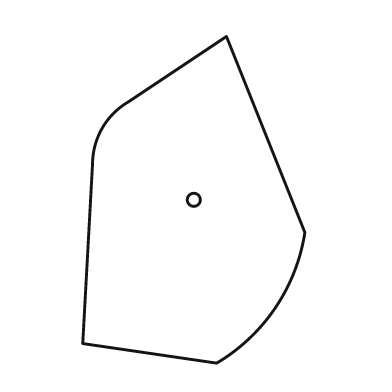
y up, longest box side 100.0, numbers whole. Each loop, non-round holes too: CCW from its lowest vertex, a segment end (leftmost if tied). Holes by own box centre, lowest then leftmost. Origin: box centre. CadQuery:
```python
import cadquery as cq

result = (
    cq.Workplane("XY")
    .moveTo(7.0, -50.0)
    .threePointArc((25.0, -33.0), (34.0, -10.0))
    .lineTo(10.0, 50.0)
    .lineTo(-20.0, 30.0)
    .threePointArc((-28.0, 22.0), (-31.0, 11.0))
    .lineTo(-34.0, -44.0)
    .close()
    .moveTo(0.0, 0.0)
    .circle(2.0)
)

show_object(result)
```